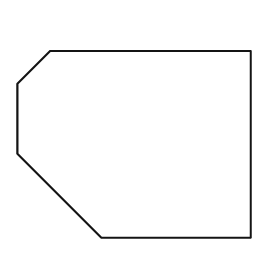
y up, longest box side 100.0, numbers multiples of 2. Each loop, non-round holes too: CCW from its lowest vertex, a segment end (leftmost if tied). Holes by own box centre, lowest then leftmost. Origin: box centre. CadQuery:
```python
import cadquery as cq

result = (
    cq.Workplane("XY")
    .moveTo(-14.0, -40.0)
    .lineTo(50.0, -40.0)
    .lineTo(50.0, 40.0)
    .lineTo(-36.0, 40.0)
    .lineTo(-50.0, 26.0)
    .lineTo(-50.0, -4.0)
    .close()
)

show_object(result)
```